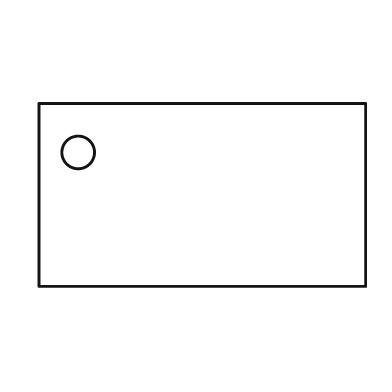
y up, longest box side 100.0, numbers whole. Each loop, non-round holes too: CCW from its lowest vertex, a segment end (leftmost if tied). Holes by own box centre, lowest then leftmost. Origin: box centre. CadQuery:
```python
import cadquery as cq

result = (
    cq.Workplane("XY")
    .moveTo(-50.0, -28.0)
    .lineTo(50.0, -28.0)
    .lineTo(50.0, 28.0)
    .lineTo(-50.0, 28.0)
    .close()
    .moveTo(-38.0, 13.0)
    .circle(5.0)
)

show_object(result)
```